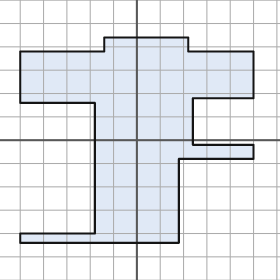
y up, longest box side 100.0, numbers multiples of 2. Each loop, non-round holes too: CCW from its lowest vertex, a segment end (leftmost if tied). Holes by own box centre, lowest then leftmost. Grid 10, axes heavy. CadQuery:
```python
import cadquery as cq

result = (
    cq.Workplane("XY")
    .moveTo(-50.0, -44.0)
    .lineTo(18.0, -44.0)
    .lineTo(18.0, -8.0)
    .lineTo(50.0, -8.0)
    .lineTo(50.0, -2.0)
    .lineTo(24.0, -2.0)
    .lineTo(24.0, 18.0)
    .lineTo(50.0, 18.0)
    .lineTo(50.0, 38.0)
    .lineTo(22.0, 38.0)
    .lineTo(22.0, 44.0)
    .lineTo(-14.0, 44.0)
    .lineTo(-14.0, 38.0)
    .lineTo(-50.0, 38.0)
    .lineTo(-50.0, 16.0)
    .lineTo(-18.0, 16.0)
    .lineTo(-18.0, -40.0)
    .lineTo(-50.0, -40.0)
    .close()
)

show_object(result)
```